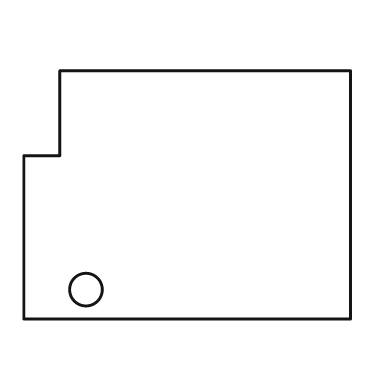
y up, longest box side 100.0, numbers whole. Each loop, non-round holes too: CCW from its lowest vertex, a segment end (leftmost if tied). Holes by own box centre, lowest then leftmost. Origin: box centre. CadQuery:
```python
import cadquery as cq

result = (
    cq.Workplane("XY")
    .moveTo(-50.0, -38.0)
    .lineTo(50.0, -38.0)
    .lineTo(50.0, 38.0)
    .lineTo(-39.0, 38.0)
    .lineTo(-39.0, 12.0)
    .lineTo(-50.0, 12.0)
    .close()
    .moveTo(-31.0, -29.0)
    .circle(5.0)
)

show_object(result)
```